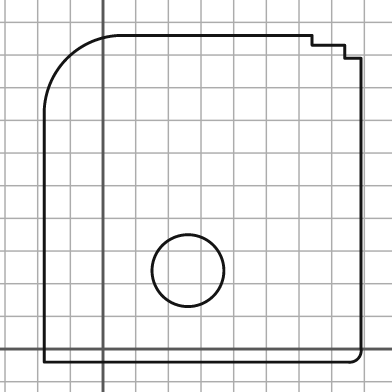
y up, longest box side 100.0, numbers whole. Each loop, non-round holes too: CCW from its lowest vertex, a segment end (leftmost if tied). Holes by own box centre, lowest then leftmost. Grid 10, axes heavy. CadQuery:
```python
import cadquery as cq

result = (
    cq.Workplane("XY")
    .moveTo(-18.0, -4.0)
    .lineTo(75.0, -4.0)
    .threePointArc((78.0, -3.0), (79.0, 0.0))
    .lineTo(79.0, 89.0)
    .lineTo(74.0, 89.0)
    .lineTo(74.0, 93.0)
    .lineTo(64.0, 93.0)
    .lineTo(64.0, 96.0)
    .lineTo(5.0, 96.0)
    .threePointArc((-11.0, 89.0), (-18.0, 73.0))
    .close()
    .moveTo(26.0, 24.0)
    .circle(11.0)
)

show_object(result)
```